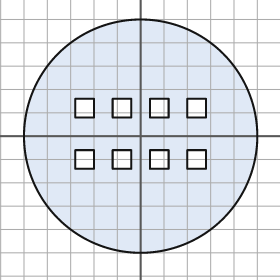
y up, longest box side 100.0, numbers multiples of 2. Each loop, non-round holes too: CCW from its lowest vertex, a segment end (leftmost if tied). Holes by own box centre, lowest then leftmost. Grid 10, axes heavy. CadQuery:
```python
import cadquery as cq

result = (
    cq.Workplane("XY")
    .moveTo(0.0, 0.0)
    .circle(50.0)
    .moveTo(-28.0, -14.0)
    .lineTo(-20.0, -14.0)
    .lineTo(-20.0, -6.0)
    .lineTo(-28.0, -6.0)
    .close()
    .moveTo(-12.0, -14.0)
    .lineTo(-4.0, -14.0)
    .lineTo(-4.0, -6.0)
    .lineTo(-12.0, -6.0)
    .close()
    .moveTo(4.0, -14.0)
    .lineTo(12.0, -14.0)
    .lineTo(12.0, -6.0)
    .lineTo(4.0, -6.0)
    .close()
    .moveTo(20.0, -14.0)
    .lineTo(28.0, -14.0)
    .lineTo(28.0, -6.0)
    .lineTo(20.0, -6.0)
    .close()
    .moveTo(-28.0, 8.0)
    .lineTo(-20.0, 8.0)
    .lineTo(-20.0, 16.0)
    .lineTo(-28.0, 16.0)
    .close()
    .moveTo(-12.0, 8.0)
    .lineTo(-4.0, 8.0)
    .lineTo(-4.0, 16.0)
    .lineTo(-12.0, 16.0)
    .close()
    .moveTo(4.0, 8.0)
    .lineTo(12.0, 8.0)
    .lineTo(12.0, 16.0)
    .lineTo(4.0, 16.0)
    .close()
    .moveTo(20.0, 8.0)
    .lineTo(28.0, 8.0)
    .lineTo(28.0, 16.0)
    .lineTo(20.0, 16.0)
    .close()
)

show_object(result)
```